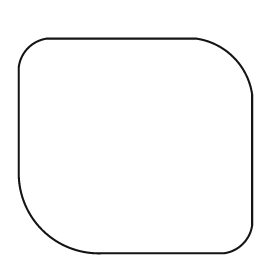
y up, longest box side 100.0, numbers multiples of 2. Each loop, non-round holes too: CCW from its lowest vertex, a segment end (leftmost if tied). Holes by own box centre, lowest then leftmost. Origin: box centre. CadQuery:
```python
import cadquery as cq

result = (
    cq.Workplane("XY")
    .moveTo(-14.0, -46.0)
    .lineTo(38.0, -46.0)
    .threePointArc((46.0, -42.0), (50.0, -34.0))
    .lineTo(50.0, 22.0)
    .threePointArc((42.0, 38.0), (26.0, 46.0))
    .lineTo(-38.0, 46.0)
    .threePointArc((-46.0, 42.0), (-50.0, 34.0))
    .lineTo(-50.0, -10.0)
    .threePointArc((-40.0, -36.0), (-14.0, -46.0))
    .close()
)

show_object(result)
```